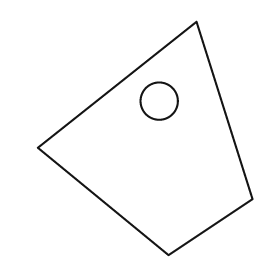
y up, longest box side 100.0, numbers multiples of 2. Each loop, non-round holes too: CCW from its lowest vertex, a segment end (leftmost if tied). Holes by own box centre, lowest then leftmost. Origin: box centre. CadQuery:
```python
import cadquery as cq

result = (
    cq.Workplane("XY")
    .moveTo(10.0, -50.0)
    .lineTo(46.0, -26.0)
    .lineTo(22.0, 50.0)
    .lineTo(-46.0, -4.0)
    .close()
    .moveTo(6.0, 16.0)
    .circle(8.0)
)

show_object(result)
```